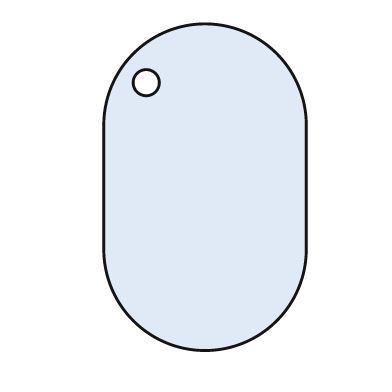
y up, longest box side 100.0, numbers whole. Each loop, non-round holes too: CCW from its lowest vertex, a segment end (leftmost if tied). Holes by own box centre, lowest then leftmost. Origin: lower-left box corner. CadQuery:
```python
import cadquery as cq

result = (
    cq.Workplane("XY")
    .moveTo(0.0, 31.0)
    .threePointArc((31.0, 0.0), (62.0, 31.0))
    .lineTo(62.0, 69.0)
    .threePointArc((31.0, 100.0), (0.0, 69.0))
    .close()
    .moveTo(13.0, 82.0)
    .circle(4.0)
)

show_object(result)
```